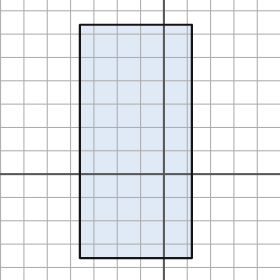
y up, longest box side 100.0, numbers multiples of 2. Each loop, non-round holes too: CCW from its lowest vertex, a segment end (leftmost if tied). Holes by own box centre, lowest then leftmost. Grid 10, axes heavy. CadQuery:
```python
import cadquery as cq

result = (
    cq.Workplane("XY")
    .moveTo(-36.0, -36.0)
    .lineTo(12.0, -36.0)
    .lineTo(12.0, 64.0)
    .lineTo(-36.0, 64.0)
    .close()
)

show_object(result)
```